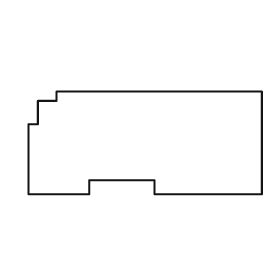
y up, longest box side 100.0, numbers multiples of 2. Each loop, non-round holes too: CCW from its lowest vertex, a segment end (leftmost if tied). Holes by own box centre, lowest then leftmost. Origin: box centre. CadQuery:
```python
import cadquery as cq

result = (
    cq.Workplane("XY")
    .moveTo(-50.0, -22.0)
    .lineTo(-24.0, -22.0)
    .lineTo(-24.0, -16.0)
    .lineTo(4.0, -16.0)
    .lineTo(4.0, -22.0)
    .lineTo(50.0, -22.0)
    .lineTo(50.0, 22.0)
    .lineTo(-38.0, 22.0)
    .lineTo(-38.0, 18.0)
    .lineTo(-46.0, 18.0)
    .lineTo(-46.0, 8.0)
    .lineTo(-50.0, 8.0)
    .close()
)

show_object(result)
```